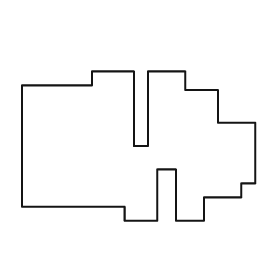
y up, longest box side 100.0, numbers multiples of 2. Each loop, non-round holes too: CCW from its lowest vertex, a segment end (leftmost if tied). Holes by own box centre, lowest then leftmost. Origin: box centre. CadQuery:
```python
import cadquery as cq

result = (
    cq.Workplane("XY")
    .moveTo(-6.0, -32.0)
    .lineTo(8.0, -32.0)
    .lineTo(8.0, -10.0)
    .lineTo(16.0, -10.0)
    .lineTo(16.0, -32.0)
    .lineTo(28.0, -32.0)
    .lineTo(28.0, -22.0)
    .lineTo(44.0, -22.0)
    .lineTo(44.0, -16.0)
    .lineTo(50.0, -16.0)
    .lineTo(50.0, 10.0)
    .lineTo(34.0, 10.0)
    .lineTo(34.0, 24.0)
    .lineTo(20.0, 24.0)
    .lineTo(20.0, 32.0)
    .lineTo(4.0, 32.0)
    .lineTo(4.0, 0.0)
    .lineTo(-2.0, 0.0)
    .lineTo(-2.0, 32.0)
    .lineTo(-20.0, 32.0)
    .lineTo(-20.0, 26.0)
    .lineTo(-50.0, 26.0)
    .lineTo(-50.0, -26.0)
    .lineTo(-6.0, -26.0)
    .close()
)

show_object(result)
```